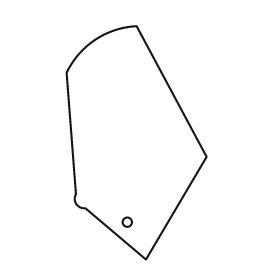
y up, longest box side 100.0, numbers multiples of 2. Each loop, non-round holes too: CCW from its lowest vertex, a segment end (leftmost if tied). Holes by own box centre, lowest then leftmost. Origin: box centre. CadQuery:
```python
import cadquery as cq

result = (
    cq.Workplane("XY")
    .moveTo(4.0, -50.0)
    .lineTo(30.0, -6.0)
    .lineTo(0.0, 50.0)
    .threePointArc((-18.0, 44.0), (-30.0, 30.0))
    .lineTo(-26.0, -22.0)
    .threePointArc((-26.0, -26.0), (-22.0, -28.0))
    .close()
    .moveTo(-4.0, -34.0)
    .circle(2.0)
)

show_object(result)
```